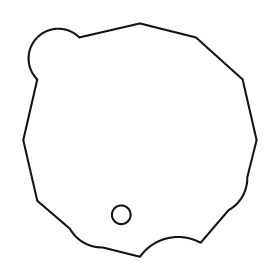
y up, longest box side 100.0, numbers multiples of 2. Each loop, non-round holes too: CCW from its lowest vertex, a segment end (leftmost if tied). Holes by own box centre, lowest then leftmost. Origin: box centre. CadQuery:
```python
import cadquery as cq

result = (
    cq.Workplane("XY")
    .moveTo(0.0, -50.0)
    .threePointArc((12.0, -42.0), (26.0, -44.0))
    .lineTo(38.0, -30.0)
    .threePointArc((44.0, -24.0), (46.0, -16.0))
    .lineTo(50.0, 0.0)
    .lineTo(44.0, 26.0)
    .lineTo(24.0, 44.0)
    .lineTo(0.0, 50.0)
    .lineTo(-26.0, 44.0)
    .threePointArc((-44.0, 44.0), (-44.0, 26.0))
    .lineTo(-50.0, 0.0)
    .lineTo(-44.0, -26.0)
    .lineTo(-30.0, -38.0)
    .threePointArc((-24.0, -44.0), (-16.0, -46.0))
    .close()
    .moveTo(-8.0, -32.0)
    .circle(4.0)
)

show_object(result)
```